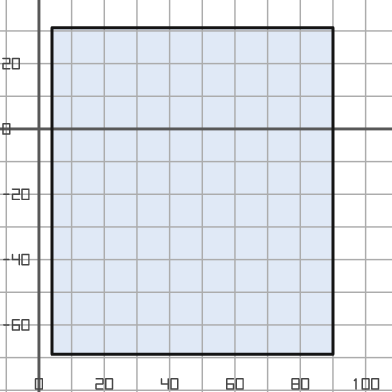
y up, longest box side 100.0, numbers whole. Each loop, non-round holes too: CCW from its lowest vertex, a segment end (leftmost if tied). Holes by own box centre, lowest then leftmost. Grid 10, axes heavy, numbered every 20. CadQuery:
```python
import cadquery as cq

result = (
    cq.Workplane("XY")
    .moveTo(4.0, -69.0)
    .lineTo(90.0, -69.0)
    .lineTo(90.0, 31.0)
    .lineTo(4.0, 31.0)
    .close()
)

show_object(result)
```